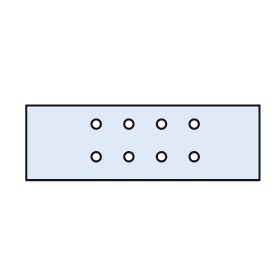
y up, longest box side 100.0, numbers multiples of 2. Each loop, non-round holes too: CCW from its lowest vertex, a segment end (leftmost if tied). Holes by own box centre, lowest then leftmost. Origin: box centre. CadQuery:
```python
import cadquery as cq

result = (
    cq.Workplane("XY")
    .moveTo(-50.0, -16.0)
    .lineTo(50.0, -16.0)
    .lineTo(50.0, 16.0)
    .lineTo(-50.0, 16.0)
    .close()
    .moveTo(-20.0, -6.0)
    .circle(2.0)
    .moveTo(-6.0, -6.0)
    .circle(2.0)
    .moveTo(8.0, -6.0)
    .circle(2.0)
    .moveTo(22.0, -6.0)
    .circle(2.0)
    .moveTo(-20.0, 8.0)
    .circle(2.0)
    .moveTo(-6.0, 8.0)
    .circle(2.0)
    .moveTo(8.0, 8.0)
    .circle(2.0)
    .moveTo(22.0, 8.0)
    .circle(2.0)
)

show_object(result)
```